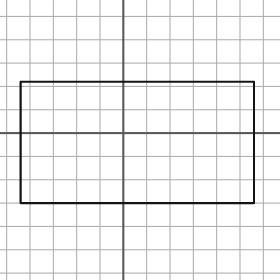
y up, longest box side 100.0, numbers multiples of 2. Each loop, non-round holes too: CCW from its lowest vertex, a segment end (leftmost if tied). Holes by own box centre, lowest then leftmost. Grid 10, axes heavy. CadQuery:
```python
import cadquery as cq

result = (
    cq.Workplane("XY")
    .moveTo(-44.0, -30.0)
    .lineTo(56.0, -30.0)
    .lineTo(56.0, 22.0)
    .lineTo(-44.0, 22.0)
    .close()
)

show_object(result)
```